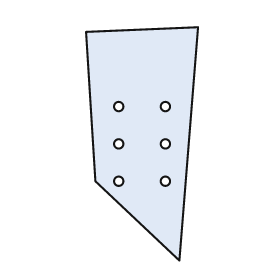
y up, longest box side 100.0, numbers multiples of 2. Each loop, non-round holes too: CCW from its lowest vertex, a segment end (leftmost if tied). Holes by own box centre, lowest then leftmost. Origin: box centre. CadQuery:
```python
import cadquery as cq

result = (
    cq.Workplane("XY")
    .moveTo(16.0, -50.0)
    .lineTo(24.0, 50.0)
    .lineTo(-24.0, 48.0)
    .lineTo(-20.0, -16.0)
    .close()
    .moveTo(-10.0, -16.0)
    .circle(2.0)
    .moveTo(10.0, -16.0)
    .circle(2.0)
    .moveTo(-10.0, 0.0)
    .circle(2.0)
    .moveTo(10.0, 0.0)
    .circle(2.0)
    .moveTo(-10.0, 16.0)
    .circle(2.0)
    .moveTo(10.0, 16.0)
    .circle(2.0)
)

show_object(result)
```